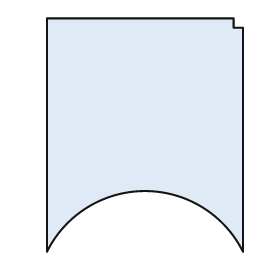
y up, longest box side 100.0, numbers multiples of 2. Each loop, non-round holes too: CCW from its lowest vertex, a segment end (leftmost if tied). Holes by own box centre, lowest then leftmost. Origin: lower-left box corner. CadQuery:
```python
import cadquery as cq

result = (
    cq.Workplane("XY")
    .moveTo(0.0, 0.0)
    .threePointArc((42.0, 26.0), (84.0, 0.0))
    .lineTo(84.0, 96.0)
    .lineTo(80.0, 96.0)
    .lineTo(80.0, 100.0)
    .lineTo(0.0, 100.0)
    .close()
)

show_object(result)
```